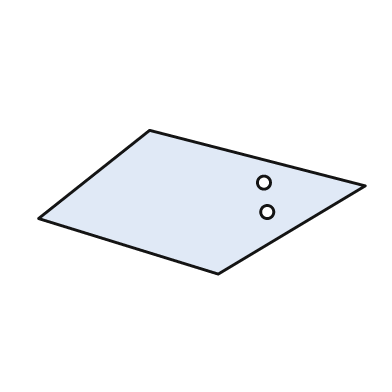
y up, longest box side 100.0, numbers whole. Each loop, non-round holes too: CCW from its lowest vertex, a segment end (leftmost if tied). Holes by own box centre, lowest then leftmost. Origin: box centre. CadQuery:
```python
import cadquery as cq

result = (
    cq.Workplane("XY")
    .moveTo(5.0, -22.0)
    .lineTo(50.0, 5.0)
    .lineTo(-16.0, 22.0)
    .lineTo(-50.0, -5.0)
    .close()
    .moveTo(20.0, -3.0)
    .circle(2.0)
    .moveTo(19.0, 6.0)
    .circle(2.0)
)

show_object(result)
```